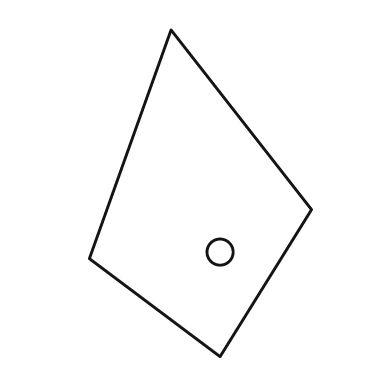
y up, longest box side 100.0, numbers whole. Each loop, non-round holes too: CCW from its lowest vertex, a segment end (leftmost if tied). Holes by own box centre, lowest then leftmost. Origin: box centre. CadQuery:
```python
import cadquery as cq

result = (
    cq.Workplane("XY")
    .moveTo(6.0, -50.0)
    .lineTo(34.0, -5.0)
    .lineTo(-9.0, 50.0)
    .lineTo(-34.0, -20.0)
    .close()
    .moveTo(6.0, -18.0)
    .circle(4.0)
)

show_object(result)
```